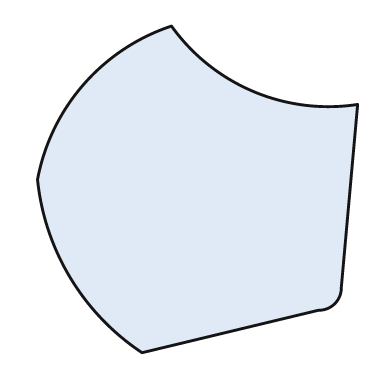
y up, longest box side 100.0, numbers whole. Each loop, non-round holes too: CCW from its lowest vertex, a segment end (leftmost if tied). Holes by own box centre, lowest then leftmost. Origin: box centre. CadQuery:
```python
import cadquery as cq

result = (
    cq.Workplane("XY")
    .moveTo(-17.0, -50.0)
    .lineTo(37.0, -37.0)
    .threePointArc((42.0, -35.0), (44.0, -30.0))
    .lineTo(49.0, 26.0)
    .threePointArc((17.0, 30.0), (-8.0, 50.0))
    .threePointArc((-35.0, 32.0), (-49.0, 3.0))
    .threePointArc((-39.0, -27.0), (-17.0, -50.0))
    .close()
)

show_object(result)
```